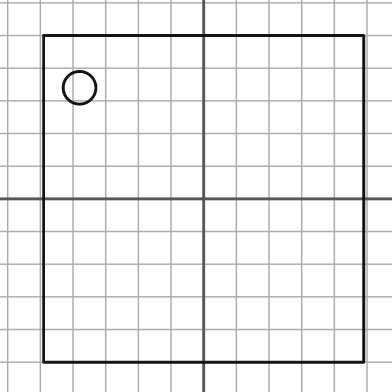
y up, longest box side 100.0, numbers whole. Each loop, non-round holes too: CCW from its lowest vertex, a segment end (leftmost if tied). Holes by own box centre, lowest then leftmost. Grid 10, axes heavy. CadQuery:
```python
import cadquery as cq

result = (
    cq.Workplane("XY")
    .moveTo(-49.0, -50.0)
    .lineTo(49.0, -50.0)
    .lineTo(49.0, 50.0)
    .lineTo(-49.0, 50.0)
    .close()
    .moveTo(-38.0, 34.0)
    .circle(5.0)
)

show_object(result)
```